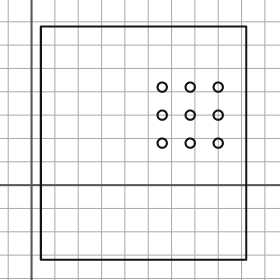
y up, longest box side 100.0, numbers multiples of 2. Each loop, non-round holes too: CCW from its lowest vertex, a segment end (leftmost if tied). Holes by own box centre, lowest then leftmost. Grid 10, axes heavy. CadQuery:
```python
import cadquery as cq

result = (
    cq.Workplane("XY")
    .moveTo(4.0, -32.0)
    .lineTo(92.0, -32.0)
    .lineTo(92.0, 68.0)
    .lineTo(4.0, 68.0)
    .close()
    .moveTo(56.0, 18.0)
    .circle(2.0)
    .moveTo(68.0, 18.0)
    .circle(2.0)
    .moveTo(80.0, 18.0)
    .circle(2.0)
    .moveTo(56.0, 30.0)
    .circle(2.0)
    .moveTo(68.0, 30.0)
    .circle(2.0)
    .moveTo(80.0, 30.0)
    .circle(2.0)
    .moveTo(56.0, 42.0)
    .circle(2.0)
    .moveTo(68.0, 42.0)
    .circle(2.0)
    .moveTo(80.0, 42.0)
    .circle(2.0)
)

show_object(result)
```